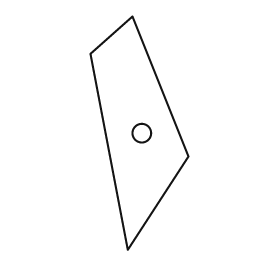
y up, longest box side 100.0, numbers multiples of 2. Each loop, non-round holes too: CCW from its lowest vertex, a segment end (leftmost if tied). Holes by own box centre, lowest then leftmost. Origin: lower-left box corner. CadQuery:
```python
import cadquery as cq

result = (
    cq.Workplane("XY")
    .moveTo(16.0, 0.0)
    .lineTo(42.0, 40.0)
    .lineTo(18.0, 100.0)
    .lineTo(0.0, 84.0)
    .close()
    .moveTo(22.0, 50.0)
    .circle(4.0)
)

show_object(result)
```